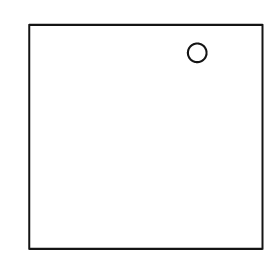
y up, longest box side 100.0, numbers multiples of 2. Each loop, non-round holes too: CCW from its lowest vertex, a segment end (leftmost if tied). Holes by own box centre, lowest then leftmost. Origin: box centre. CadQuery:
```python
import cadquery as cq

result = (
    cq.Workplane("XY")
    .moveTo(-50.0, -48.0)
    .lineTo(50.0, -48.0)
    .lineTo(50.0, 48.0)
    .lineTo(-50.0, 48.0)
    .close()
    .moveTo(22.0, 36.0)
    .circle(4.0)
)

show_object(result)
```